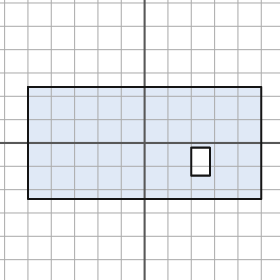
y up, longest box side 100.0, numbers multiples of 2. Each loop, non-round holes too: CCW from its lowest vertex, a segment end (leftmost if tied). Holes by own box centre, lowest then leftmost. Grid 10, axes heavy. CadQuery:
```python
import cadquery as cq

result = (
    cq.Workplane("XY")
    .moveTo(-50.0, -24.0)
    .lineTo(50.0, -24.0)
    .lineTo(50.0, 24.0)
    .lineTo(-50.0, 24.0)
    .close()
    .moveTo(20.0, -14.0)
    .lineTo(28.0, -14.0)
    .lineTo(28.0, -2.0)
    .lineTo(20.0, -2.0)
    .close()
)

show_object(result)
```